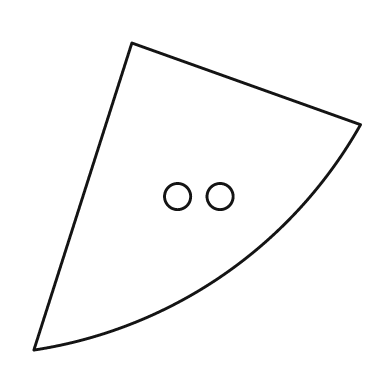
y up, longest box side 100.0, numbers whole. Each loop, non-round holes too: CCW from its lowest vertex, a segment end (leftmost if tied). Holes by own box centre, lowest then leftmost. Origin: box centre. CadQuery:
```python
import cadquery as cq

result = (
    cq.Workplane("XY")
    .moveTo(-50.0, -47.0)
    .threePointArc((8.0, -24.0), (50.0, 22.0))
    .lineTo(-20.0, 47.0)
    .close()
    .moveTo(-6.0, 0.0)
    .circle(4.0)
    .moveTo(7.0, 0.0)
    .circle(4.0)
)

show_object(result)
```